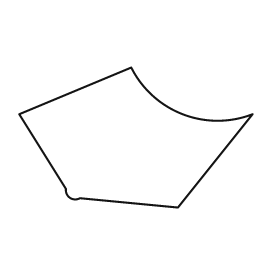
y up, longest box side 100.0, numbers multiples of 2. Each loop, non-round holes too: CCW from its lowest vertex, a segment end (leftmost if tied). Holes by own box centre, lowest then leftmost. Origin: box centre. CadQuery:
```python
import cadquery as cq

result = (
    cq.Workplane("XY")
    .moveTo(18.0, -30.0)
    .lineTo(50.0, 10.0)
    .threePointArc((20.0, 10.0), (-2.0, 30.0))
    .lineTo(-50.0, 10.0)
    .lineTo(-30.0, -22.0)
    .threePointArc((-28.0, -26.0), (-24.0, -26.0))
    .close()
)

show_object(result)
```